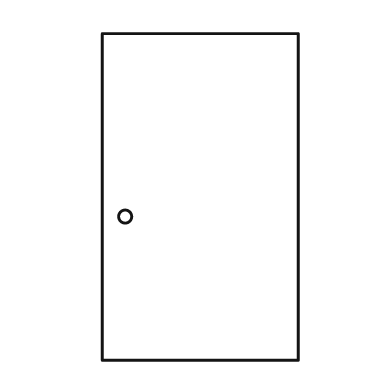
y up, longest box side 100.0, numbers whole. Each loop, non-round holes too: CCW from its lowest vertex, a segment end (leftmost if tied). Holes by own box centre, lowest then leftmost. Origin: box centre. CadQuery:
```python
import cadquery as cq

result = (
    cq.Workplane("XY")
    .moveTo(-30.0, -50.0)
    .lineTo(30.0, -50.0)
    .lineTo(30.0, 50.0)
    .lineTo(-30.0, 50.0)
    .close()
    .moveTo(-23.0, -6.0)
    .circle(2.0)
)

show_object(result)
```